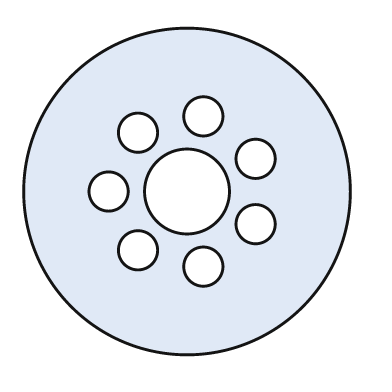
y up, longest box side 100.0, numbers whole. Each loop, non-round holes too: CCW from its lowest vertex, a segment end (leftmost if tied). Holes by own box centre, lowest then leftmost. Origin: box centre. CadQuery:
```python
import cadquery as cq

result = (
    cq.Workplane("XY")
    .moveTo(0.0, 0.0)
    .circle(50.0)
    .moveTo(5.0, -23.0)
    .circle(6.0)
    .moveTo(-15.0, -18.0)
    .circle(6.0)
    .moveTo(21.0, -10.0)
    .circle(6.0)
    .moveTo(-24.0, 0.0)
    .circle(6.0)
    .moveTo(0.0, 0.0)
    .circle(13.0)
    .moveTo(21.0, 10.0)
    .circle(6.0)
    .moveTo(-15.0, 18.0)
    .circle(6.0)
    .moveTo(5.0, 23.0)
    .circle(6.0)
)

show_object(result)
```